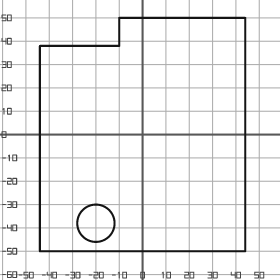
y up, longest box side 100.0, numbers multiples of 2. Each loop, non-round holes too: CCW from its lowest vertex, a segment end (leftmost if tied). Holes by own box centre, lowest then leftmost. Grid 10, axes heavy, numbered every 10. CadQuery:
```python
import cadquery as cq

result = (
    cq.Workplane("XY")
    .moveTo(-44.0, -50.0)
    .lineTo(44.0, -50.0)
    .lineTo(44.0, 50.0)
    .lineTo(-10.0, 50.0)
    .lineTo(-10.0, 38.0)
    .lineTo(-44.0, 38.0)
    .close()
    .moveTo(-20.0, -38.0)
    .circle(8.0)
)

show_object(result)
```